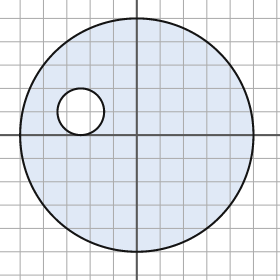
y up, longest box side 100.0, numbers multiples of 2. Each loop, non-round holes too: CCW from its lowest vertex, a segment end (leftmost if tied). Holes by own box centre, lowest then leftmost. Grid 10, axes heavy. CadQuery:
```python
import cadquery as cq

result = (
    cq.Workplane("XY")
    .moveTo(0.0, 0.0)
    .circle(50.0)
    .moveTo(-24.0, 10.0)
    .circle(10.0)
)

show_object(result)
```